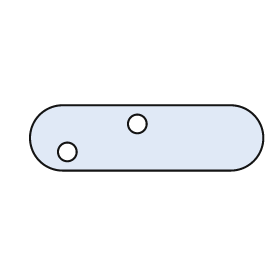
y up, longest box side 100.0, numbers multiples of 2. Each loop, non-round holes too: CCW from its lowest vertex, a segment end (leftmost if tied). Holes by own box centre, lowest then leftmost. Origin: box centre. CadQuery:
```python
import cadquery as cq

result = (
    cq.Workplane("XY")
    .moveTo(-36.0, -14.0)
    .lineTo(36.0, -14.0)
    .threePointArc((50.0, 0.0), (36.0, 14.0))
    .lineTo(-36.0, 14.0)
    .threePointArc((-50.0, 0.0), (-36.0, -14.0))
    .close()
    .moveTo(-34.0, -6.0)
    .circle(4.0)
    .moveTo(-4.0, 6.0)
    .circle(4.0)
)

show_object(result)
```